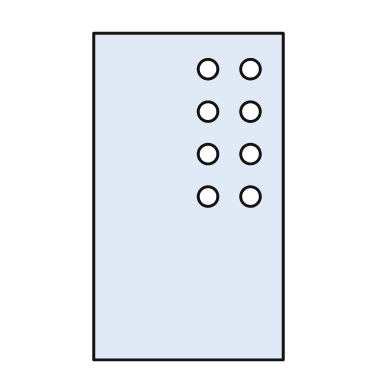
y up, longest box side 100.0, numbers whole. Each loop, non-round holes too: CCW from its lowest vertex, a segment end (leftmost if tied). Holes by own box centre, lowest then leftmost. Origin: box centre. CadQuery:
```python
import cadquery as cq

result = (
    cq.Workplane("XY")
    .moveTo(-29.0, -50.0)
    .lineTo(29.0, -50.0)
    .lineTo(29.0, 50.0)
    .lineTo(-29.0, 50.0)
    .close()
    .moveTo(6.0, 0.0)
    .circle(3.0)
    .moveTo(19.0, 0.0)
    .circle(3.0)
    .moveTo(6.0, 13.0)
    .circle(3.0)
    .moveTo(19.0, 13.0)
    .circle(3.0)
    .moveTo(6.0, 26.0)
    .circle(3.0)
    .moveTo(19.0, 26.0)
    .circle(3.0)
    .moveTo(6.0, 39.0)
    .circle(3.0)
    .moveTo(19.0, 39.0)
    .circle(3.0)
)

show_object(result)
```